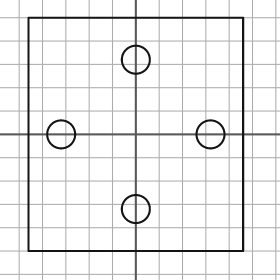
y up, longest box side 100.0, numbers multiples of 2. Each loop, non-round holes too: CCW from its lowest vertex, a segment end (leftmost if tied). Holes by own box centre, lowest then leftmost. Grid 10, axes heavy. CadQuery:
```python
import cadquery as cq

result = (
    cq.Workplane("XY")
    .moveTo(-46.0, -50.0)
    .lineTo(46.0, -50.0)
    .lineTo(46.0, 50.0)
    .lineTo(-46.0, 50.0)
    .close()
    .moveTo(0.0, -32.0)
    .circle(6.0)
    .moveTo(-32.0, 0.0)
    .circle(6.0)
    .moveTo(32.0, 0.0)
    .circle(6.0)
    .moveTo(0.0, 32.0)
    .circle(6.0)
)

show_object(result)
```